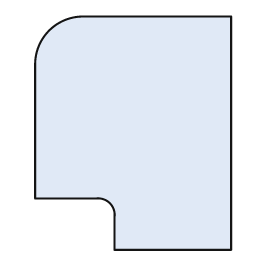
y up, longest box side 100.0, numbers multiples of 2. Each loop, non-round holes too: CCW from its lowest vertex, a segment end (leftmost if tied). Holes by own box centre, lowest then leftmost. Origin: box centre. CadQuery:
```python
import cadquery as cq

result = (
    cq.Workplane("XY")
    .moveTo(-8.0, -50.0)
    .lineTo(42.0, -50.0)
    .lineTo(42.0, 50.0)
    .lineTo(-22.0, 50.0)
    .threePointArc((-36.0, 44.0), (-42.0, 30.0))
    .lineTo(-42.0, -28.0)
    .lineTo(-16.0, -28.0)
    .threePointArc((-10.0, -30.0), (-8.0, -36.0))
    .close()
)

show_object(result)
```